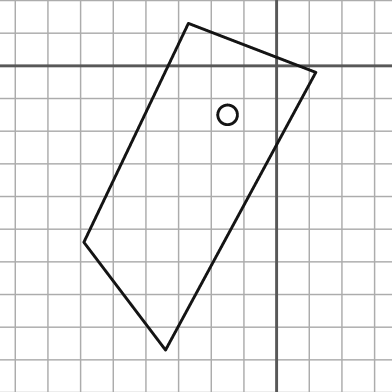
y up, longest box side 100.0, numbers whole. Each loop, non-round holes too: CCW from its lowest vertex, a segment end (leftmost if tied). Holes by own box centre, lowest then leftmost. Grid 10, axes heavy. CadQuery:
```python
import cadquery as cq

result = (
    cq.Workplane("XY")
    .moveTo(-34.0, -87.0)
    .lineTo(12.0, -2.0)
    .lineTo(-27.0, 13.0)
    .lineTo(-59.0, -54.0)
    .close()
    .moveTo(-15.0, -15.0)
    .circle(3.0)
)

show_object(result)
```